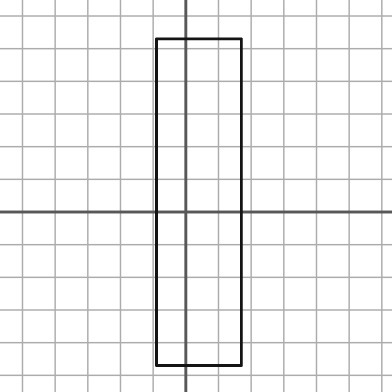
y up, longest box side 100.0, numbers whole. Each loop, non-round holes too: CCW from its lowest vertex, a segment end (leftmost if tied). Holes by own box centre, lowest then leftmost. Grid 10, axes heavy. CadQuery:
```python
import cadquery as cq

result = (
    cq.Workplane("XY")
    .moveTo(-9.0, -47.0)
    .lineTo(17.0, -47.0)
    .lineTo(17.0, 53.0)
    .lineTo(-9.0, 53.0)
    .close()
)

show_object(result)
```